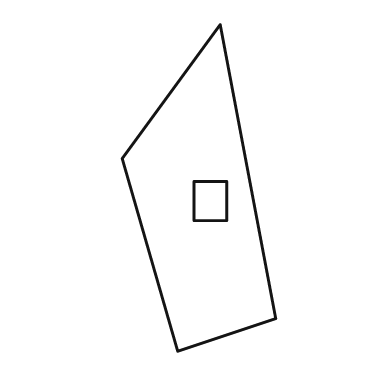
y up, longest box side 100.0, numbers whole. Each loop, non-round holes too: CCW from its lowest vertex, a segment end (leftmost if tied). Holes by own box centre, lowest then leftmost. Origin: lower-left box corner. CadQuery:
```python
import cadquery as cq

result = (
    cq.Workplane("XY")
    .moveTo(17.0, 0.0)
    .lineTo(47.0, 10.0)
    .lineTo(30.0, 100.0)
    .lineTo(0.0, 59.0)
    .close()
    .moveTo(22.0, 40.0)
    .lineTo(32.0, 40.0)
    .lineTo(32.0, 52.0)
    .lineTo(22.0, 52.0)
    .close()
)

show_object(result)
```